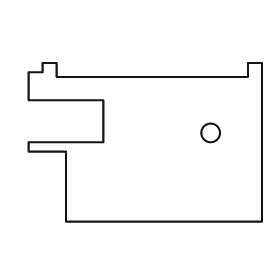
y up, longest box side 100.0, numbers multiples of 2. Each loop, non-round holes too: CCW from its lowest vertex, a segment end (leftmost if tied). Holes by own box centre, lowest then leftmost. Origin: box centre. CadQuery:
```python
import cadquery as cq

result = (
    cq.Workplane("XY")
    .moveTo(-34.0, -34.0)
    .lineTo(50.0, -34.0)
    .lineTo(50.0, 34.0)
    .lineTo(44.0, 34.0)
    .lineTo(44.0, 28.0)
    .lineTo(-38.0, 28.0)
    .lineTo(-38.0, 34.0)
    .lineTo(-44.0, 34.0)
    .lineTo(-44.0, 30.0)
    .lineTo(-50.0, 30.0)
    .lineTo(-50.0, 18.0)
    .lineTo(-18.0, 18.0)
    .lineTo(-18.0, 0.0)
    .lineTo(-50.0, 0.0)
    .lineTo(-50.0, -4.0)
    .lineTo(-34.0, -4.0)
    .close()
    .moveTo(28.0, 4.0)
    .circle(4.0)
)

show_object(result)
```